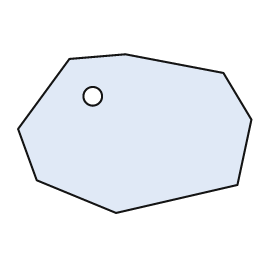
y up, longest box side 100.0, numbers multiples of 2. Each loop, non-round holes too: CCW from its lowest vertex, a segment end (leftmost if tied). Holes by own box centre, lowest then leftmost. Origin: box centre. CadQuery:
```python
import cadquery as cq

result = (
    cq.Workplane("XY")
    .moveTo(-8.0, -34.0)
    .lineTo(44.0, -22.0)
    .lineTo(50.0, 6.0)
    .lineTo(38.0, 26.0)
    .lineTo(-4.0, 34.0)
    .lineTo(-28.0, 32.0)
    .lineTo(-50.0, 2.0)
    .lineTo(-42.0, -20.0)
    .close()
    .moveTo(-18.0, 16.0)
    .circle(4.0)
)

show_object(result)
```